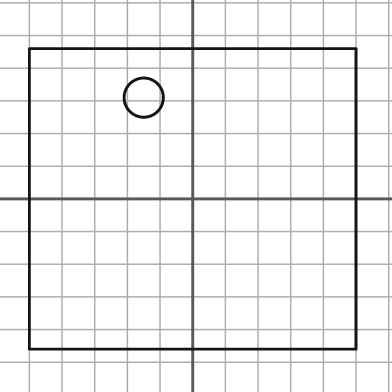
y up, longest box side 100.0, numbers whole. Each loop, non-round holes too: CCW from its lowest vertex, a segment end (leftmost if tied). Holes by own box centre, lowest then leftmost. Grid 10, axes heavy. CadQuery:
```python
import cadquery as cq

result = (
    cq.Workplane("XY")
    .moveTo(-50.0, -46.0)
    .lineTo(50.0, -46.0)
    .lineTo(50.0, 46.0)
    .lineTo(-50.0, 46.0)
    .close()
    .moveTo(-15.0, 31.0)
    .circle(6.0)
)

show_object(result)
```